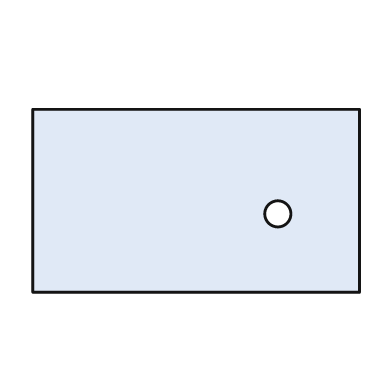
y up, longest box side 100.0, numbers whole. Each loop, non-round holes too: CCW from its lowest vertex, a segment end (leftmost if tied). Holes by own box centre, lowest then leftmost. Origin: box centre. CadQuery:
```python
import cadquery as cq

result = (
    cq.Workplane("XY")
    .moveTo(-50.0, -28.0)
    .lineTo(50.0, -28.0)
    .lineTo(50.0, 28.0)
    .lineTo(-50.0, 28.0)
    .close()
    .moveTo(25.0, -4.0)
    .circle(4.0)
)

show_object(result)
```